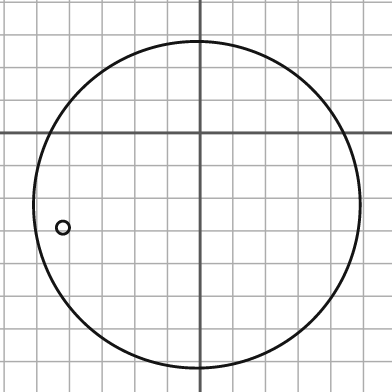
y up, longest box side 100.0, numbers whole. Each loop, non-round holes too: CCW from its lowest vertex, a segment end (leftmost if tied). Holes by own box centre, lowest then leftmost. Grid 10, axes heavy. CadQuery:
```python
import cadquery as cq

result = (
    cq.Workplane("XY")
    .moveTo(-1.0, -22.0)
    .circle(50.0)
    .moveTo(-42.0, -29.0)
    .circle(2.0)
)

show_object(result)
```